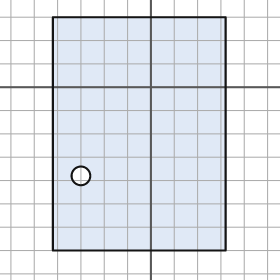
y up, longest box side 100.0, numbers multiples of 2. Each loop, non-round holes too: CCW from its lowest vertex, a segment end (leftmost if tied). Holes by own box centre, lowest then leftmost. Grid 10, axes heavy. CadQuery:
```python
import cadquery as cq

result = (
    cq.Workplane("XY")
    .moveTo(-42.0, -70.0)
    .lineTo(32.0, -70.0)
    .lineTo(32.0, 30.0)
    .lineTo(-42.0, 30.0)
    .close()
    .moveTo(-30.0, -38.0)
    .circle(4.0)
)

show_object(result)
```